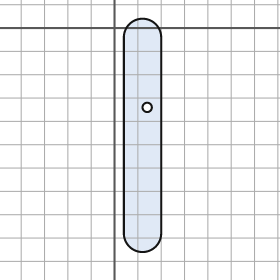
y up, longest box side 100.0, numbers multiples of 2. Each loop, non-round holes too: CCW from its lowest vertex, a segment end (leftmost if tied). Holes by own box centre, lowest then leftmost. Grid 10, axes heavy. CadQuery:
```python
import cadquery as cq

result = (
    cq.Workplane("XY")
    .moveTo(4.0, -88.0)
    .threePointArc((12.0, -96.0), (20.0, -88.0))
    .lineTo(20.0, -4.0)
    .threePointArc((12.0, 4.0), (4.0, -4.0))
    .close()
    .moveTo(14.0, -34.0)
    .circle(2.0)
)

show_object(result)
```